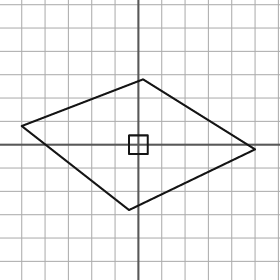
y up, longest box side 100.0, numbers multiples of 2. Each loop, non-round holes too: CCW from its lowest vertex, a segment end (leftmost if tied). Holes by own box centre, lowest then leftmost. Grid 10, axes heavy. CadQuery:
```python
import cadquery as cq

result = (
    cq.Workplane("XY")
    .moveTo(-4.0, -28.0)
    .lineTo(50.0, -2.0)
    .lineTo(2.0, 28.0)
    .lineTo(-50.0, 8.0)
    .close()
    .moveTo(-4.0, -4.0)
    .lineTo(4.0, -4.0)
    .lineTo(4.0, 4.0)
    .lineTo(-4.0, 4.0)
    .close()
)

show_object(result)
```